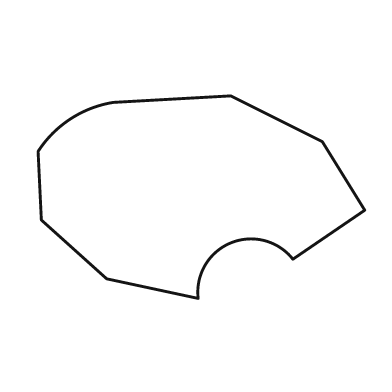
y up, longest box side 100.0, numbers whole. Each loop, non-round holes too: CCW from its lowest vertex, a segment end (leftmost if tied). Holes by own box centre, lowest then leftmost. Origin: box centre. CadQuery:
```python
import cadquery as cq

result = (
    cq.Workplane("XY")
    .moveTo(-1.0, -31.0)
    .threePointArc((9.0, -14.0), (28.0, -19.0))
    .lineTo(50.0, -4.0)
    .lineTo(37.0, 17.0)
    .lineTo(9.0, 31.0)
    .lineTo(-27.0, 29.0)
    .threePointArc((-40.0, 24.0), (-50.0, 14.0))
    .lineTo(-49.0, -7.0)
    .lineTo(-29.0, -25.0)
    .close()
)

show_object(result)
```